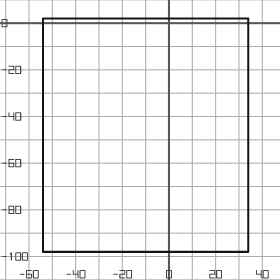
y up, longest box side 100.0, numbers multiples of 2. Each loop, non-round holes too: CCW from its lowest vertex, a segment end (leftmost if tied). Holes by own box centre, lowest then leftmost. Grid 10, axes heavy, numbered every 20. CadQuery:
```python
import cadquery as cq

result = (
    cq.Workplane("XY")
    .moveTo(-54.0, -98.0)
    .lineTo(34.0, -98.0)
    .lineTo(34.0, 2.0)
    .lineTo(-54.0, 2.0)
    .close()
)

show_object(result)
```